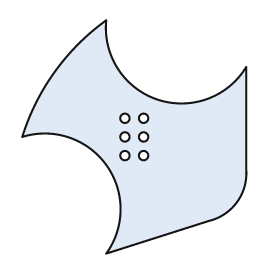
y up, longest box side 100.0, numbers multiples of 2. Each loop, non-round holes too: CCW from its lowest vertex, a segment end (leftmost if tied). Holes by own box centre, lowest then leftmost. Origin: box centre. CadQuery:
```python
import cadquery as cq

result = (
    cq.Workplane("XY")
    .moveTo(-12.0, -50.0)
    .lineTo(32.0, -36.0)
    .threePointArc((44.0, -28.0), (48.0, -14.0))
    .lineTo(48.0, 30.0)
    .threePointArc((10.0, 16.0), (-12.0, 50.0))
    .threePointArc((-34.0, 28.0), (-48.0, 0.0))
    .threePointArc((-12.0, -12.0), (-12.0, -50.0))
    .close()
    .moveTo(-4.0, -8.0)
    .circle(2.0)
    .moveTo(4.0, -8.0)
    .circle(2.0)
    .moveTo(-4.0, 0.0)
    .circle(2.0)
    .moveTo(4.0, 0.0)
    .circle(2.0)
    .moveTo(-4.0, 8.0)
    .circle(2.0)
    .moveTo(4.0, 8.0)
    .circle(2.0)
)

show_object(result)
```